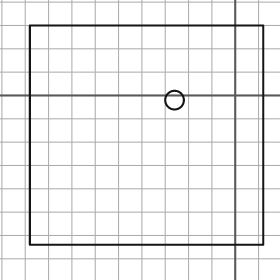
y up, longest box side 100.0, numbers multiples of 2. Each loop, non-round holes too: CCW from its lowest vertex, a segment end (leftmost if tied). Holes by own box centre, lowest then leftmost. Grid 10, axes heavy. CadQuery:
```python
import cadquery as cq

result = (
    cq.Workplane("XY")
    .moveTo(-88.0, -64.0)
    .lineTo(12.0, -64.0)
    .lineTo(12.0, 30.0)
    .lineTo(-88.0, 30.0)
    .close()
    .moveTo(-26.0, -2.0)
    .circle(4.0)
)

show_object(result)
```